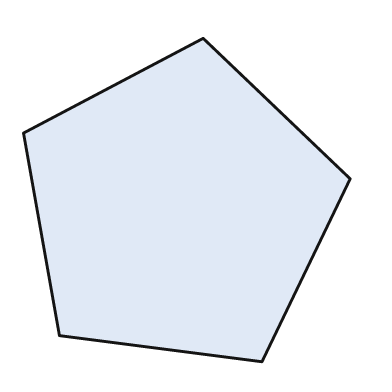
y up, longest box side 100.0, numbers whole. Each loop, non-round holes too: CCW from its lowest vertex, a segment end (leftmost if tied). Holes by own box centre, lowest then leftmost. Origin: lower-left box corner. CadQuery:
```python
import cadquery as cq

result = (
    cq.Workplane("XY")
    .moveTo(73.0, 0.0)
    .lineTo(100.0, 56.0)
    .lineTo(55.0, 99.0)
    .lineTo(0.0, 70.0)
    .lineTo(11.0, 8.0)
    .close()
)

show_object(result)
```